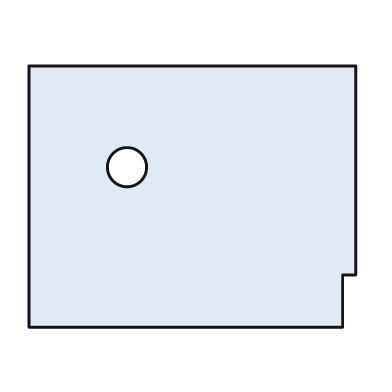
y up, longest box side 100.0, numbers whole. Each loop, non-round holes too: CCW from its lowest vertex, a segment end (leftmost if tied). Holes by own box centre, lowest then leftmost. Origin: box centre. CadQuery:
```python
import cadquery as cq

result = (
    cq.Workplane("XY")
    .moveTo(-50.0, -40.0)
    .lineTo(46.0, -40.0)
    .lineTo(46.0, -24.0)
    .lineTo(50.0, -24.0)
    .lineTo(50.0, 40.0)
    .lineTo(-50.0, 40.0)
    .close()
    .moveTo(-20.0, 9.0)
    .circle(6.0)
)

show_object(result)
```